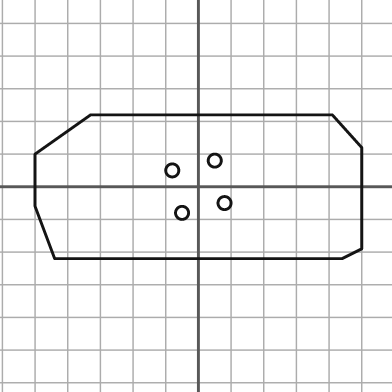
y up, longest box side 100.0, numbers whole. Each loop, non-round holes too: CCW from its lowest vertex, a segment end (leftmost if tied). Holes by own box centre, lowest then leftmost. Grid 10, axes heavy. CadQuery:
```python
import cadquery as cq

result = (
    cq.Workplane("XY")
    .moveTo(-44.0, -22.0)
    .lineTo(44.0, -22.0)
    .lineTo(50.0, -19.0)
    .lineTo(50.0, 12.0)
    .lineTo(41.0, 22.0)
    .lineTo(-33.0, 22.0)
    .lineTo(-50.0, 10.0)
    .lineTo(-50.0, -6.0)
    .close()
    .moveTo(-5.0, -8.0)
    .circle(2.0)
    .moveTo(8.0, -5.0)
    .circle(2.0)
    .moveTo(-8.0, 5.0)
    .circle(2.0)
    .moveTo(5.0, 8.0)
    .circle(2.0)
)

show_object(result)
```